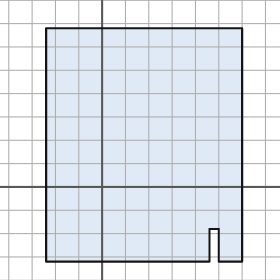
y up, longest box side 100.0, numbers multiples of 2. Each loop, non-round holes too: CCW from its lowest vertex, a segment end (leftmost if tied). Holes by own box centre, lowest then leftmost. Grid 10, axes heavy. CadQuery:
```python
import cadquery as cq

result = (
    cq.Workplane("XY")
    .moveTo(-24.0, -32.0)
    .lineTo(46.0, -32.0)
    .lineTo(46.0, -18.0)
    .lineTo(50.0, -18.0)
    .lineTo(50.0, -32.0)
    .lineTo(60.0, -32.0)
    .lineTo(60.0, 68.0)
    .lineTo(-24.0, 68.0)
    .close()
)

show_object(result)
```